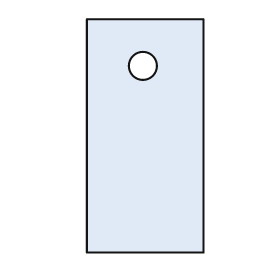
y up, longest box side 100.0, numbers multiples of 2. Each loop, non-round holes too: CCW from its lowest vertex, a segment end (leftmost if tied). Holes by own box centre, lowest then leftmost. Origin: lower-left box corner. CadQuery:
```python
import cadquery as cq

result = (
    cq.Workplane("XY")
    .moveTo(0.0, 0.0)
    .lineTo(50.0, 0.0)
    .lineTo(50.0, 100.0)
    .lineTo(0.0, 100.0)
    .close()
    .moveTo(24.0, 80.0)
    .circle(6.0)
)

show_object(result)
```